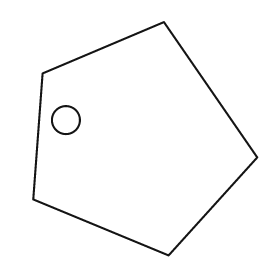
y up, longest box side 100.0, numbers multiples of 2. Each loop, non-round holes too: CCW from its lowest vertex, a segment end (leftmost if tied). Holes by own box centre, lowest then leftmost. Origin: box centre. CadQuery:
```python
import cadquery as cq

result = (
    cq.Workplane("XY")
    .moveTo(10.0, -50.0)
    .lineTo(48.0, -8.0)
    .lineTo(8.0, 50.0)
    .lineTo(-44.0, 28.0)
    .lineTo(-48.0, -26.0)
    .close()
    .moveTo(-34.0, 8.0)
    .circle(6.0)
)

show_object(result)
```